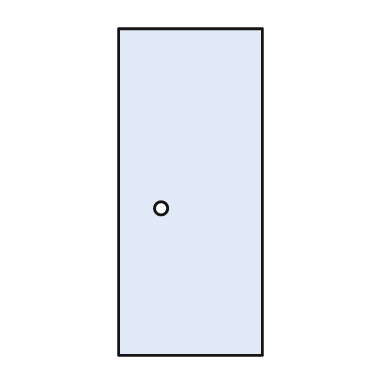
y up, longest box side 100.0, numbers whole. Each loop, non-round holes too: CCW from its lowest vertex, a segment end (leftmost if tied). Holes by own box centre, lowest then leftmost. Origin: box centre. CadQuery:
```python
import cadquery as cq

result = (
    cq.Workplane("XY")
    .moveTo(-22.0, -50.0)
    .lineTo(22.0, -50.0)
    .lineTo(22.0, 50.0)
    .lineTo(-22.0, 50.0)
    .close()
    .moveTo(-9.0, -5.0)
    .circle(2.0)
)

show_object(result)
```